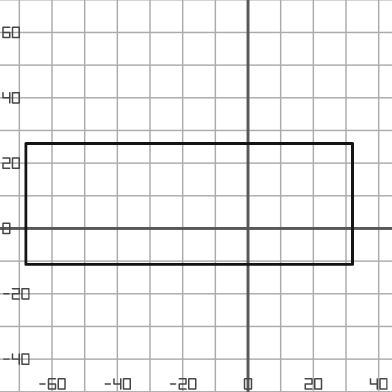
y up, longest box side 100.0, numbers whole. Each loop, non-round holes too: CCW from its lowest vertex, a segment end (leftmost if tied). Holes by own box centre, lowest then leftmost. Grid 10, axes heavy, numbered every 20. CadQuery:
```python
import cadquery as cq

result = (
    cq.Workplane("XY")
    .moveTo(-68.0, -11.0)
    .lineTo(32.0, -11.0)
    .lineTo(32.0, 26.0)
    .lineTo(-68.0, 26.0)
    .close()
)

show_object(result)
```